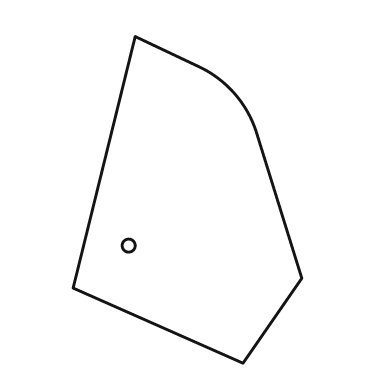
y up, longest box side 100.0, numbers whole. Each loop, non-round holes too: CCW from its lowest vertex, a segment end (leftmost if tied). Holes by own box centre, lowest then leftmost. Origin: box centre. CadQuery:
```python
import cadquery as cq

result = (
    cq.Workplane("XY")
    .moveTo(17.0, -50.0)
    .lineTo(35.0, -24.0)
    .lineTo(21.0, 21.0)
    .threePointArc((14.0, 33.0), (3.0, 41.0))
    .lineTo(-16.0, 50.0)
    .lineTo(-35.0, -27.0)
    .close()
    .moveTo(-18.0, -14.0)
    .circle(2.0)
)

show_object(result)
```